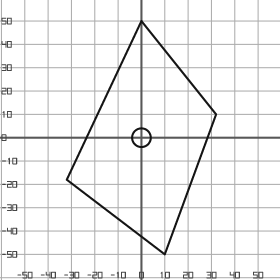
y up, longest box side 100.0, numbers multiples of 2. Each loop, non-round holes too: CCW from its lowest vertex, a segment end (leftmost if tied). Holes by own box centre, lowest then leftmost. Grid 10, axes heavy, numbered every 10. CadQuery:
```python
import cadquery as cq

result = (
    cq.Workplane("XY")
    .moveTo(10.0, -50.0)
    .lineTo(32.0, 10.0)
    .lineTo(0.0, 50.0)
    .lineTo(-32.0, -18.0)
    .close()
    .moveTo(0.0, 0.0)
    .circle(4.0)
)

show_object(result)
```